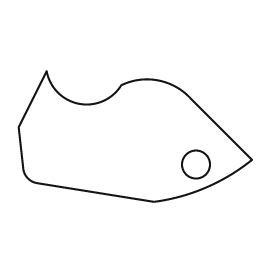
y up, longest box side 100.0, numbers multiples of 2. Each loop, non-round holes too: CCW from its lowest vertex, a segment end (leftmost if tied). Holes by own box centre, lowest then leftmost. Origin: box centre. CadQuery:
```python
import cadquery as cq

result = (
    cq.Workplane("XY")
    .moveTo(8.0, -28.0)
    .threePointArc((30.0, -22.0), (50.0, -10.0))
    .lineTo(24.0, 16.0)
    .threePointArc((10.0, 24.0), (-6.0, 22.0))
    .threePointArc((-24.0, 14.0), (-38.0, 28.0))
    .lineTo(-50.0, 4.0)
    .lineTo(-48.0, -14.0)
    .threePointArc((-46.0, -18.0), (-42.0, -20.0))
    .close()
    .moveTo(26.0, -12.0)
    .circle(6.0)
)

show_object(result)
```